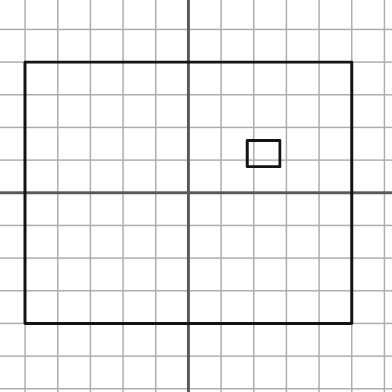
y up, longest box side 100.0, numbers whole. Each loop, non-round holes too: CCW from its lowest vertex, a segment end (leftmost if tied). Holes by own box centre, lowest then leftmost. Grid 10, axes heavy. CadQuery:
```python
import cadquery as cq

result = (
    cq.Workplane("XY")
    .moveTo(-50.0, -40.0)
    .lineTo(50.0, -40.0)
    .lineTo(50.0, 40.0)
    .lineTo(-50.0, 40.0)
    .close()
    .moveTo(18.0, 8.0)
    .lineTo(28.0, 8.0)
    .lineTo(28.0, 16.0)
    .lineTo(18.0, 16.0)
    .close()
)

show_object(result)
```